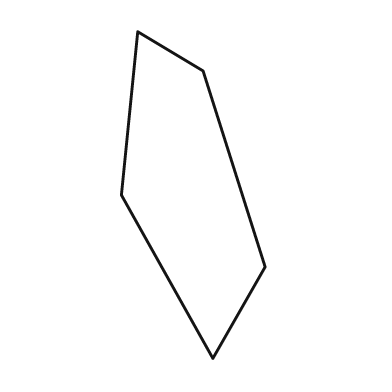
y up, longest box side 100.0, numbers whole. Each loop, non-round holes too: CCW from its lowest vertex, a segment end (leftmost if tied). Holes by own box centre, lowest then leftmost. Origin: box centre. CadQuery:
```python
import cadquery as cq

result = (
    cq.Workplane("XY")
    .moveTo(6.0, -50.0)
    .lineTo(22.0, -22.0)
    .lineTo(3.0, 38.0)
    .lineTo(-17.0, 50.0)
    .lineTo(-22.0, 0.0)
    .close()
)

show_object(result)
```